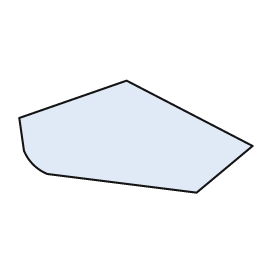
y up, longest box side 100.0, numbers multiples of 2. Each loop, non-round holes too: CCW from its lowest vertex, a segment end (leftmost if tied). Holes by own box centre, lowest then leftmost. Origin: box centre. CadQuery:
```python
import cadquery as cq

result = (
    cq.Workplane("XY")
    .moveTo(26.0, -24.0)
    .lineTo(50.0, -4.0)
    .lineTo(-4.0, 24.0)
    .lineTo(-50.0, 8.0)
    .lineTo(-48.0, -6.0)
    .threePointArc((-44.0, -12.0), (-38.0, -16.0))
    .close()
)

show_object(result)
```